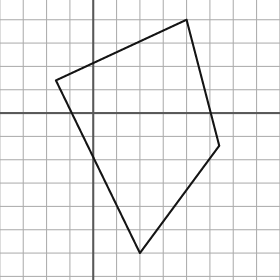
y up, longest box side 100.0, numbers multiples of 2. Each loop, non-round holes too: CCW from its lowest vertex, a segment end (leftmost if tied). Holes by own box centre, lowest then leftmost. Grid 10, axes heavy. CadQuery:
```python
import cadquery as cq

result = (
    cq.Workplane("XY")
    .moveTo(20.0, -60.0)
    .lineTo(54.0, -14.0)
    .lineTo(40.0, 40.0)
    .lineTo(-16.0, 14.0)
    .close()
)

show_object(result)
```